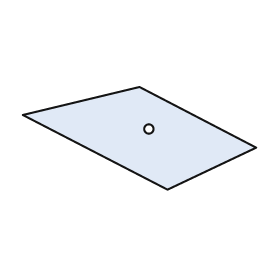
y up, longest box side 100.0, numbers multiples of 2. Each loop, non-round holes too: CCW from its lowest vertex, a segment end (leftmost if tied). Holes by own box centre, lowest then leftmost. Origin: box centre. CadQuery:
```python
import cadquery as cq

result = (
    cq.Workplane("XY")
    .moveTo(12.0, -22.0)
    .lineTo(50.0, -4.0)
    .lineTo(0.0, 22.0)
    .lineTo(-50.0, 10.0)
    .close()
    .moveTo(4.0, 4.0)
    .circle(2.0)
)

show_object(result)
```